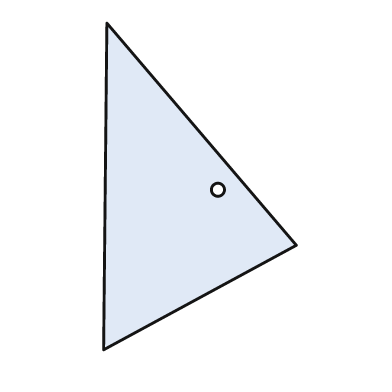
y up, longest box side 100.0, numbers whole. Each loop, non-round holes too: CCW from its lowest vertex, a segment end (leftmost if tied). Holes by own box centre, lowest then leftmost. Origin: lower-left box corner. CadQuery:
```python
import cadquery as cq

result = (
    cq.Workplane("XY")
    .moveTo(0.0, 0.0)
    .lineTo(59.0, 32.0)
    .lineTo(1.0, 100.0)
    .close()
    .moveTo(35.0, 49.0)
    .circle(2.0)
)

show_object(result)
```